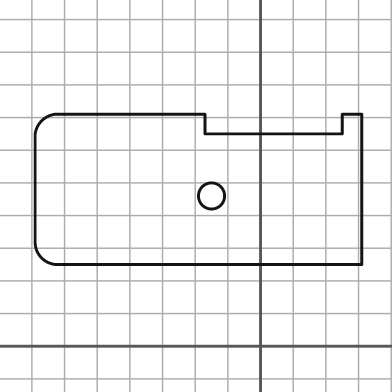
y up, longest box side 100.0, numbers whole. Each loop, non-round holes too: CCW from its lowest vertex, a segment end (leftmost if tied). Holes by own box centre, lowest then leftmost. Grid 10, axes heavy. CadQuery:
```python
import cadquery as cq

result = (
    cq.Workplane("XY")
    .moveTo(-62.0, 25.0)
    .lineTo(31.0, 25.0)
    .lineTo(31.0, 71.0)
    .lineTo(25.0, 71.0)
    .lineTo(25.0, 65.0)
    .lineTo(-17.0, 65.0)
    .lineTo(-17.0, 71.0)
    .lineTo(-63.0, 71.0)
    .threePointArc((-67.0, 69.0), (-69.0, 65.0))
    .lineTo(-69.0, 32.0)
    .threePointArc((-67.0, 27.0), (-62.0, 25.0))
    .close()
    .moveTo(-15.0, 46.0)
    .circle(4.0)
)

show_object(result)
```